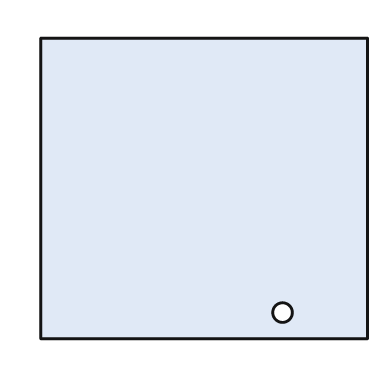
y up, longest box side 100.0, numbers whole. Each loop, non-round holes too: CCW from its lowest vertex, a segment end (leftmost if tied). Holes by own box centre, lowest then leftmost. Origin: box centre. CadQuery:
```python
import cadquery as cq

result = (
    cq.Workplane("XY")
    .moveTo(-50.0, -46.0)
    .lineTo(50.0, -46.0)
    .lineTo(50.0, 46.0)
    .lineTo(-50.0, 46.0)
    .close()
    .moveTo(24.0, -38.0)
    .circle(3.0)
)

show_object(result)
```